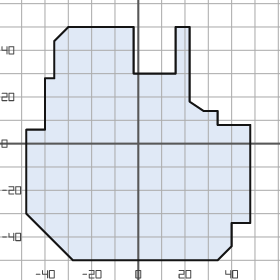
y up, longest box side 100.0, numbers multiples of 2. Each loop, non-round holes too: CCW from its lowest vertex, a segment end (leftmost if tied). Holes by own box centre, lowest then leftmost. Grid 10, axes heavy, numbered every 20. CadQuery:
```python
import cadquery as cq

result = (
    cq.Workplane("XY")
    .moveTo(-28.0, -50.0)
    .lineTo(34.0, -50.0)
    .lineTo(40.0, -44.0)
    .lineTo(40.0, -34.0)
    .lineTo(48.0, -34.0)
    .lineTo(48.0, 8.0)
    .lineTo(34.0, 8.0)
    .lineTo(34.0, 14.0)
    .lineTo(28.0, 14.0)
    .lineTo(22.0, 18.0)
    .lineTo(22.0, 50.0)
    .lineTo(16.0, 50.0)
    .lineTo(16.0, 30.0)
    .lineTo(-2.0, 30.0)
    .lineTo(-2.0, 50.0)
    .lineTo(-30.0, 50.0)
    .lineTo(-36.0, 44.0)
    .lineTo(-36.0, 28.0)
    .lineTo(-40.0, 28.0)
    .lineTo(-40.0, 6.0)
    .lineTo(-48.0, 6.0)
    .lineTo(-48.0, -30.0)
    .close()
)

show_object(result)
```